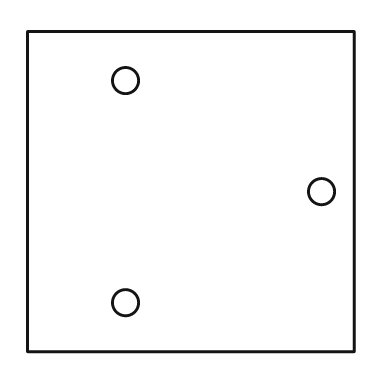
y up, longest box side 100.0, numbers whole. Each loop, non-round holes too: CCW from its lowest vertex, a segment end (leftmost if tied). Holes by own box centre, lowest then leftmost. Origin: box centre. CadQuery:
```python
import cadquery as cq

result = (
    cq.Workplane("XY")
    .moveTo(-50.0, -49.0)
    .lineTo(50.0, -49.0)
    .lineTo(50.0, 49.0)
    .lineTo(-50.0, 49.0)
    .close()
    .moveTo(-20.0, -34.0)
    .circle(4.0)
    .moveTo(40.0, 0.0)
    .circle(4.0)
    .moveTo(-20.0, 34.0)
    .circle(4.0)
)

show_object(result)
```